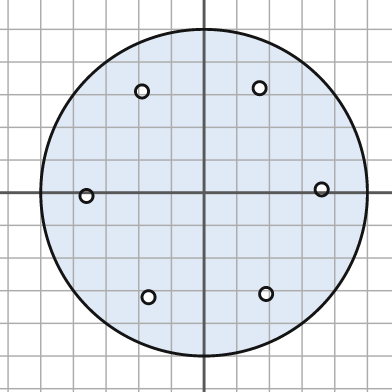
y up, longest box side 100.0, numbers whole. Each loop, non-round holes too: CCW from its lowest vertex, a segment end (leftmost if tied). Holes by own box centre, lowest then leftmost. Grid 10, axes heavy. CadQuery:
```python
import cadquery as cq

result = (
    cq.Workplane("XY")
    .moveTo(0.0, 0.0)
    .circle(50.0)
    .moveTo(-17.0, -32.0)
    .circle(2.0)
    .moveTo(19.0, -31.0)
    .circle(2.0)
    .moveTo(-36.0, -1.0)
    .circle(2.0)
    .moveTo(36.0, 1.0)
    .circle(2.0)
    .moveTo(-19.0, 31.0)
    .circle(2.0)
    .moveTo(17.0, 32.0)
    .circle(2.0)
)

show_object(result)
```